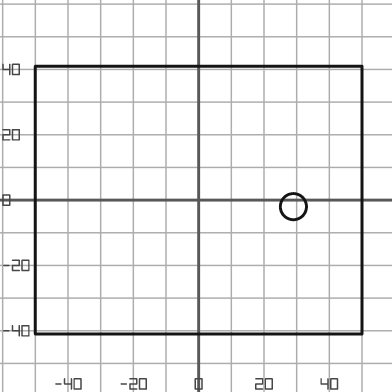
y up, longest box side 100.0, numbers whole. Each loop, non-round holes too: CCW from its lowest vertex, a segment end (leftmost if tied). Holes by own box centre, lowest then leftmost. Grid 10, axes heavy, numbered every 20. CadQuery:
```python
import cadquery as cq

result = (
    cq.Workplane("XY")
    .moveTo(-50.0, -41.0)
    .lineTo(50.0, -41.0)
    .lineTo(50.0, 41.0)
    .lineTo(-50.0, 41.0)
    .close()
    .moveTo(29.0, -2.0)
    .circle(4.0)
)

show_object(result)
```